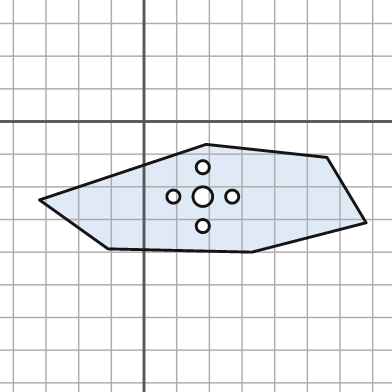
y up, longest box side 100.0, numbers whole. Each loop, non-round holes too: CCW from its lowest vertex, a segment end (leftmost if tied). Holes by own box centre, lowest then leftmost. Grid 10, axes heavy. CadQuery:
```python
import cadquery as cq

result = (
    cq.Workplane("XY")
    .moveTo(33.0, -40.0)
    .lineTo(68.0, -31.0)
    .lineTo(56.0, -11.0)
    .lineTo(19.0, -7.0)
    .lineTo(-32.0, -24.0)
    .lineTo(-11.0, -39.0)
    .close()
    .moveTo(18.0, -32.0)
    .circle(2.0)
    .moveTo(9.0, -23.0)
    .circle(2.0)
    .moveTo(18.0, -23.0)
    .circle(3.0)
    .moveTo(27.0, -23.0)
    .circle(2.0)
    .moveTo(18.0, -14.0)
    .circle(2.0)
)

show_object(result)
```